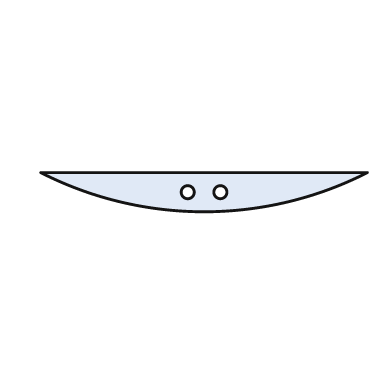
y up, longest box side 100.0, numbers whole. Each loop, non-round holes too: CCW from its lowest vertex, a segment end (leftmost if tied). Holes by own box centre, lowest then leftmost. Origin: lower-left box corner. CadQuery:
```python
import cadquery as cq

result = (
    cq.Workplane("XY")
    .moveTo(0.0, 12.0)
    .threePointArc((50.0, 0.0), (100.0, 12.0))
    .close()
    .moveTo(45.0, 6.0)
    .circle(2.0)
    .moveTo(55.0, 6.0)
    .circle(2.0)
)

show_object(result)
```